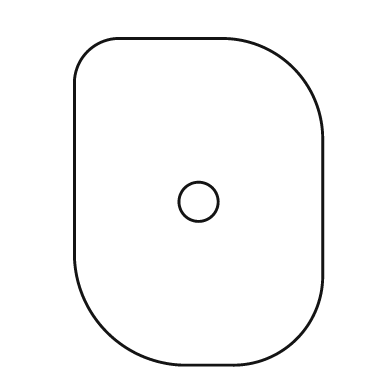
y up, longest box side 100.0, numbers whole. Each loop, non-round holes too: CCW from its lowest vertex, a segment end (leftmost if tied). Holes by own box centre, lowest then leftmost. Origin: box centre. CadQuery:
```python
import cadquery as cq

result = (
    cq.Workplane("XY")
    .moveTo(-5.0, -50.0)
    .lineTo(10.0, -50.0)
    .threePointArc((30.0, -42.0), (38.0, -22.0))
    .lineTo(38.0, 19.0)
    .threePointArc((29.0, 41.0), (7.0, 50.0))
    .lineTo(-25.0, 50.0)
    .threePointArc((-34.0, 46.0), (-38.0, 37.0))
    .lineTo(-38.0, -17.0)
    .threePointArc((-28.0, -40.0), (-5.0, -50.0))
    .close()
    .moveTo(0.0, 0.0)
    .circle(6.0)
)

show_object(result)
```